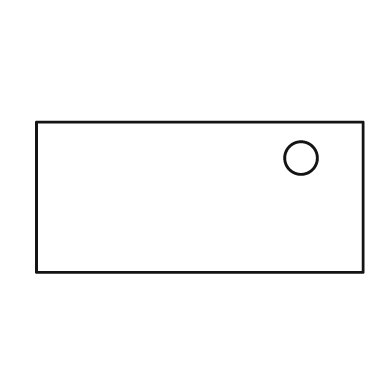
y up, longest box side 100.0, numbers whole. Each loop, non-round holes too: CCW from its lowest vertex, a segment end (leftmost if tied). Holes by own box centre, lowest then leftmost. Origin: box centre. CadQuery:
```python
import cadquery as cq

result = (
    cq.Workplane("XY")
    .moveTo(-50.0, -23.0)
    .lineTo(50.0, -23.0)
    .lineTo(50.0, 23.0)
    .lineTo(-50.0, 23.0)
    .close()
    .moveTo(31.0, 12.0)
    .circle(5.0)
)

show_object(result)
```